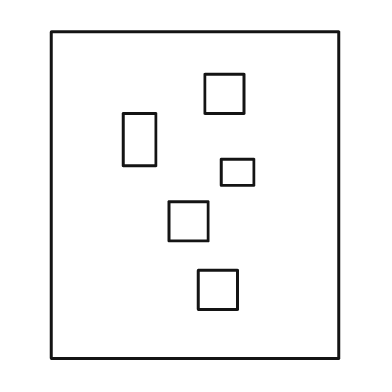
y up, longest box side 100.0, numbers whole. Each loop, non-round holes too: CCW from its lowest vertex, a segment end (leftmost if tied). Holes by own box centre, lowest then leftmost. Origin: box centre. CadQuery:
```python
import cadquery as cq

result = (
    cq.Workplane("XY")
    .moveTo(-44.0, -50.0)
    .lineTo(44.0, -50.0)
    .lineTo(44.0, 50.0)
    .lineTo(-44.0, 50.0)
    .close()
    .moveTo(1.0, -35.0)
    .lineTo(13.0, -35.0)
    .lineTo(13.0, -23.0)
    .lineTo(1.0, -23.0)
    .close()
    .moveTo(-8.0, -14.0)
    .lineTo(4.0, -14.0)
    .lineTo(4.0, -2.0)
    .lineTo(-8.0, -2.0)
    .close()
    .moveTo(8.0, 3.0)
    .lineTo(18.0, 3.0)
    .lineTo(18.0, 11.0)
    .lineTo(8.0, 11.0)
    .close()
    .moveTo(-22.0, 9.0)
    .lineTo(-12.0, 9.0)
    .lineTo(-12.0, 25.0)
    .lineTo(-22.0, 25.0)
    .close()
    .moveTo(3.0, 25.0)
    .lineTo(15.0, 25.0)
    .lineTo(15.0, 37.0)
    .lineTo(3.0, 37.0)
    .close()
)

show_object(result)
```